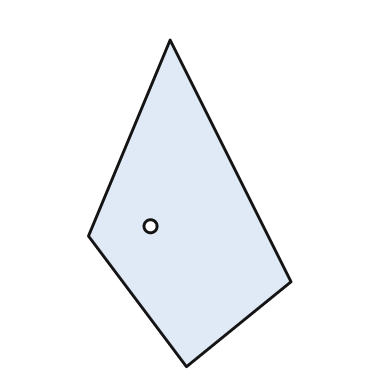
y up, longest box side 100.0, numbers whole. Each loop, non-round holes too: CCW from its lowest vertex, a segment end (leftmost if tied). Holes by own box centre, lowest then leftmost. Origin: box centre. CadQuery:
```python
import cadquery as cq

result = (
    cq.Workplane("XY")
    .moveTo(-1.0, -50.0)
    .lineTo(31.0, -24.0)
    .lineTo(-6.0, 50.0)
    .lineTo(-31.0, -10.0)
    .close()
    .moveTo(-12.0, -7.0)
    .circle(2.0)
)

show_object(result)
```